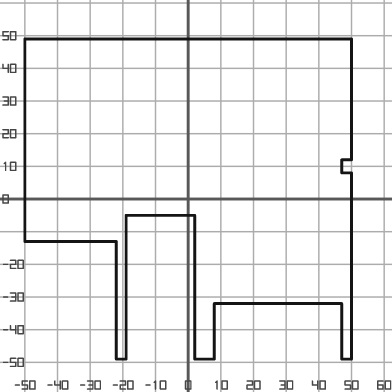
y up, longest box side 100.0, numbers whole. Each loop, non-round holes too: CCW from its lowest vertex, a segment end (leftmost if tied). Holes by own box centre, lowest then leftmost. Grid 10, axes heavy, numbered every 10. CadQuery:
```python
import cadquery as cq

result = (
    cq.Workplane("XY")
    .moveTo(-22.0, -49.0)
    .lineTo(-19.0, -49.0)
    .lineTo(-19.0, -5.0)
    .lineTo(2.0, -5.0)
    .lineTo(2.0, -49.0)
    .lineTo(8.0, -49.0)
    .lineTo(8.0, -32.0)
    .lineTo(47.0, -32.0)
    .lineTo(47.0, -49.0)
    .lineTo(50.0, -49.0)
    .lineTo(50.0, 8.0)
    .lineTo(47.0, 8.0)
    .lineTo(47.0, 12.0)
    .lineTo(50.0, 12.0)
    .lineTo(50.0, 49.0)
    .lineTo(-50.0, 49.0)
    .lineTo(-50.0, -13.0)
    .lineTo(-22.0, -13.0)
    .close()
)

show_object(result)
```